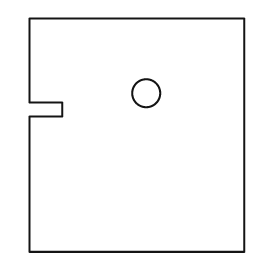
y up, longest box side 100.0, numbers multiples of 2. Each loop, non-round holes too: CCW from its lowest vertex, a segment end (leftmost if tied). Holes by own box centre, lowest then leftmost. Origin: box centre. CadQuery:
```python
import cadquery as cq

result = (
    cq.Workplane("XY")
    .moveTo(-46.0, -50.0)
    .lineTo(46.0, -50.0)
    .lineTo(46.0, 50.0)
    .lineTo(-46.0, 50.0)
    .lineTo(-46.0, 14.0)
    .lineTo(-32.0, 14.0)
    .lineTo(-32.0, 8.0)
    .lineTo(-46.0, 8.0)
    .close()
    .moveTo(4.0, 18.0)
    .circle(6.0)
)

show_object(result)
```